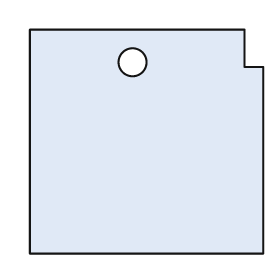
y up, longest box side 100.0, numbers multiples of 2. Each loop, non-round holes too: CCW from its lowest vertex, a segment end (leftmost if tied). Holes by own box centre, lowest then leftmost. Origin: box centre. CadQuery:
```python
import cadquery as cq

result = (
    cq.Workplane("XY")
    .moveTo(-50.0, -48.0)
    .lineTo(50.0, -48.0)
    .lineTo(50.0, 32.0)
    .lineTo(42.0, 32.0)
    .lineTo(42.0, 48.0)
    .lineTo(-50.0, 48.0)
    .close()
    .moveTo(-6.0, 34.0)
    .circle(6.0)
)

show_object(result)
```